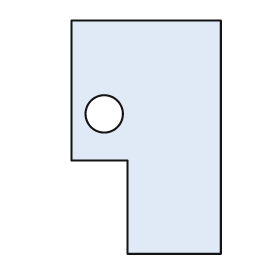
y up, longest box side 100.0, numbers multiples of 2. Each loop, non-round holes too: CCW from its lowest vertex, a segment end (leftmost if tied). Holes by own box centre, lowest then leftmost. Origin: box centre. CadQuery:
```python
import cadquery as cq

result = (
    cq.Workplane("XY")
    .moveTo(-8.0, -50.0)
    .lineTo(32.0, -50.0)
    .lineTo(32.0, 50.0)
    .lineTo(-32.0, 50.0)
    .lineTo(-32.0, -10.0)
    .lineTo(-8.0, -10.0)
    .close()
    .moveTo(-18.0, 10.0)
    .circle(8.0)
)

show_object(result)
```